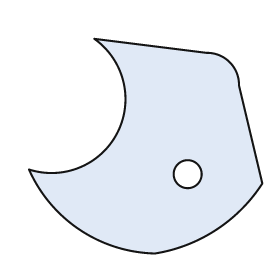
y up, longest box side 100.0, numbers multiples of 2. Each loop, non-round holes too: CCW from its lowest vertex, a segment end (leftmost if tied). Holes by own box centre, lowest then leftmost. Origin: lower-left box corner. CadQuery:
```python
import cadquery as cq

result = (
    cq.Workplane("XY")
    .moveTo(54.0, 0.0)
    .threePointArc((80.0, 10.0), (100.0, 30.0))
    .lineTo(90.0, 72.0)
    .threePointArc((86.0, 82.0), (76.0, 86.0))
    .lineTo(28.0, 92.0)
    .threePointArc((38.0, 52.0), (0.0, 36.0))
    .threePointArc((22.0, 10.0), (54.0, 0.0))
    .close()
    .moveTo(68.0, 34.0)
    .circle(6.0)
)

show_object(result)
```